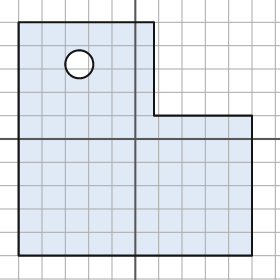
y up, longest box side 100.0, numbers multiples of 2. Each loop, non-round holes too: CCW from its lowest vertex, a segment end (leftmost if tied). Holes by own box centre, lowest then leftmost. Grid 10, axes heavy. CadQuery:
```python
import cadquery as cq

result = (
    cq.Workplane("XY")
    .moveTo(-50.0, -50.0)
    .lineTo(50.0, -50.0)
    .lineTo(50.0, 10.0)
    .lineTo(8.0, 10.0)
    .lineTo(8.0, 50.0)
    .lineTo(-50.0, 50.0)
    .close()
    .moveTo(-24.0, 32.0)
    .circle(6.0)
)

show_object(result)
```